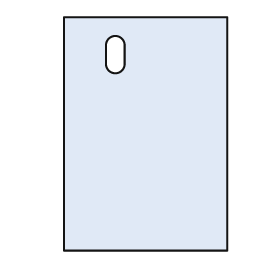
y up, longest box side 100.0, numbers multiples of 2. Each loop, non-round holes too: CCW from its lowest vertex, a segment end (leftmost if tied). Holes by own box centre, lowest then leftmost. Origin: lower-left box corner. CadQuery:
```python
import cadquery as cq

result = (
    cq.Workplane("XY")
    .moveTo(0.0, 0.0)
    .lineTo(70.0, 0.0)
    .lineTo(70.0, 100.0)
    .lineTo(0.0, 100.0)
    .close()
    .moveTo(18.0, 80.0)
    .threePointArc((22.0, 76.0), (26.0, 80.0))
    .lineTo(26.0, 88.0)
    .threePointArc((22.0, 92.0), (18.0, 88.0))
    .close()
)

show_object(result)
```